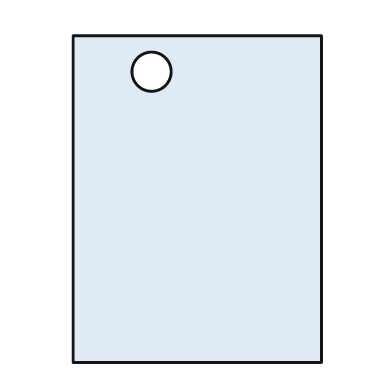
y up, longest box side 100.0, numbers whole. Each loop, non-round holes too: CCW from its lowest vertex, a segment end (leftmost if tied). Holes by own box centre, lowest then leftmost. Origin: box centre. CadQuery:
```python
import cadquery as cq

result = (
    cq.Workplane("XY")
    .moveTo(-38.0, -50.0)
    .lineTo(38.0, -50.0)
    .lineTo(38.0, 50.0)
    .lineTo(-38.0, 50.0)
    .close()
    .moveTo(-14.0, 39.0)
    .circle(6.0)
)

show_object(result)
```